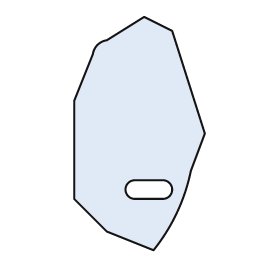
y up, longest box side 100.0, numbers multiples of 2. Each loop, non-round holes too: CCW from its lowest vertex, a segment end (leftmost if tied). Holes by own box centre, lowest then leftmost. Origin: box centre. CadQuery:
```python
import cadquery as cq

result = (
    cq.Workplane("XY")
    .moveTo(6.0, -50.0)
    .threePointArc((16.0, -34.0), (22.0, -16.0))
    .lineTo(28.0, 0.0)
    .lineTo(14.0, 44.0)
    .lineTo(2.0, 50.0)
    .lineTo(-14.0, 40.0)
    .threePointArc((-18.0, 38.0), (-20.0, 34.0))
    .lineTo(-28.0, 14.0)
    .lineTo(-28.0, -28.0)
    .lineTo(-14.0, -42.0)
    .close()
    .moveTo(-2.0, -28.0)
    .lineTo(10.0, -28.0)
    .threePointArc((14.0, -24.0), (10.0, -20.0))
    .lineTo(-2.0, -20.0)
    .threePointArc((-6.0, -24.0), (-2.0, -28.0))
    .close()
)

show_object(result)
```